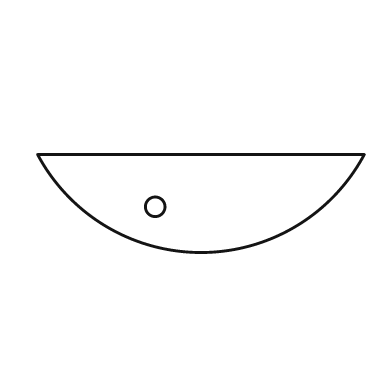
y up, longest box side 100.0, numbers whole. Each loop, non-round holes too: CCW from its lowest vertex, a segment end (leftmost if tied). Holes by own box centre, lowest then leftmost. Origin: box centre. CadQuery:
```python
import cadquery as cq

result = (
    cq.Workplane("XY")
    .moveTo(-50.0, 15.0)
    .threePointArc((0.0, -15.0), (50.0, 15.0))
    .close()
    .moveTo(-14.0, -1.0)
    .circle(3.0)
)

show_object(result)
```